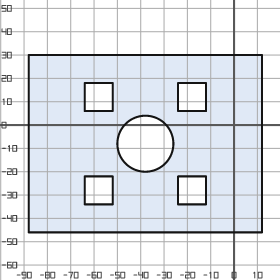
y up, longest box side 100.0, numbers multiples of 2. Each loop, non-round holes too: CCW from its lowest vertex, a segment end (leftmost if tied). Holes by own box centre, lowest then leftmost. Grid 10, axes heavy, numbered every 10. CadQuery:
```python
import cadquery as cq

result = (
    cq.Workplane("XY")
    .moveTo(-88.0, -46.0)
    .lineTo(12.0, -46.0)
    .lineTo(12.0, 30.0)
    .lineTo(-88.0, 30.0)
    .close()
    .moveTo(-64.0, -34.0)
    .lineTo(-52.0, -34.0)
    .lineTo(-52.0, -22.0)
    .lineTo(-64.0, -22.0)
    .close()
    .moveTo(-24.0, -34.0)
    .lineTo(-12.0, -34.0)
    .lineTo(-12.0, -22.0)
    .lineTo(-24.0, -22.0)
    .close()
    .moveTo(-38.0, -8.0)
    .circle(12.0)
    .moveTo(-64.0, 6.0)
    .lineTo(-52.0, 6.0)
    .lineTo(-52.0, 18.0)
    .lineTo(-64.0, 18.0)
    .close()
    .moveTo(-24.0, 6.0)
    .lineTo(-12.0, 6.0)
    .lineTo(-12.0, 18.0)
    .lineTo(-24.0, 18.0)
    .close()
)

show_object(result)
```